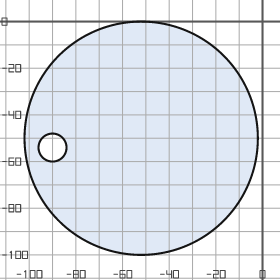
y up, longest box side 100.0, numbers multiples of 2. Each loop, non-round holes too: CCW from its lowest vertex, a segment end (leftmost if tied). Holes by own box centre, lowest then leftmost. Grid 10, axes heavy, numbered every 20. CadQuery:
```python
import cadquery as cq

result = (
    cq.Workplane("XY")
    .moveTo(-52.0, -50.0)
    .circle(50.0)
    .moveTo(-90.0, -54.0)
    .circle(6.0)
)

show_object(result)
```